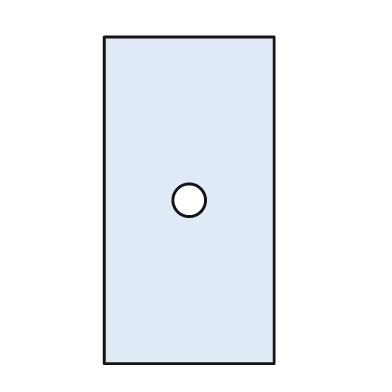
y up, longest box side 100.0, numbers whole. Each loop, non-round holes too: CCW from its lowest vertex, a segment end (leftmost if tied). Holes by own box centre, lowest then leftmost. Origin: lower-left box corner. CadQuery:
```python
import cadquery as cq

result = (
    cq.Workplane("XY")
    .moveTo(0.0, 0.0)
    .lineTo(52.0, 0.0)
    .lineTo(52.0, 100.0)
    .lineTo(0.0, 100.0)
    .close()
    .moveTo(26.0, 50.0)
    .circle(5.0)
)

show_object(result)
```